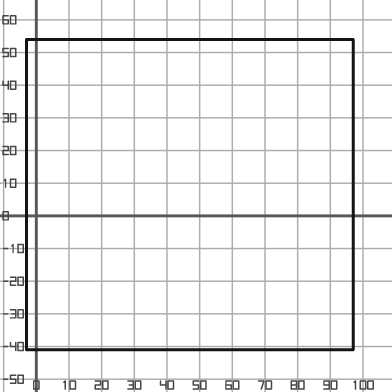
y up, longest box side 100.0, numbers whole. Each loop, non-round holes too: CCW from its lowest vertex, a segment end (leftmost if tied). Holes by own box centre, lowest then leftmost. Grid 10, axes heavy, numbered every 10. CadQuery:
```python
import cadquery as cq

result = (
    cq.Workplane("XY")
    .moveTo(-3.0, -41.0)
    .lineTo(97.0, -41.0)
    .lineTo(97.0, 54.0)
    .lineTo(-3.0, 54.0)
    .close()
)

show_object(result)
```